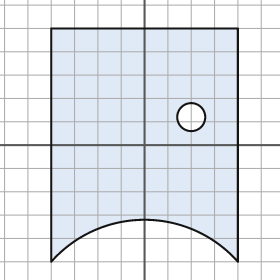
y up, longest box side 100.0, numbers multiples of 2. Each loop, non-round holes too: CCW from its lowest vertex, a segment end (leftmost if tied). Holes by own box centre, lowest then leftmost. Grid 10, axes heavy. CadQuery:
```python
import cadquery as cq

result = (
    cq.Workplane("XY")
    .moveTo(-40.0, -50.0)
    .threePointArc((0.0, -32.0), (40.0, -50.0))
    .lineTo(40.0, 50.0)
    .lineTo(-40.0, 50.0)
    .close()
    .moveTo(20.0, 12.0)
    .circle(6.0)
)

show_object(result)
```